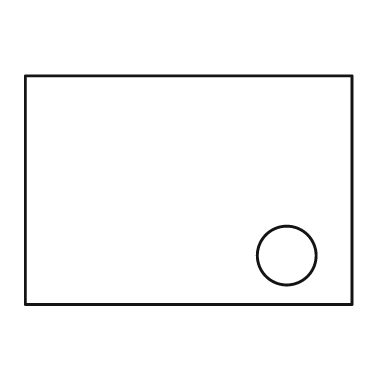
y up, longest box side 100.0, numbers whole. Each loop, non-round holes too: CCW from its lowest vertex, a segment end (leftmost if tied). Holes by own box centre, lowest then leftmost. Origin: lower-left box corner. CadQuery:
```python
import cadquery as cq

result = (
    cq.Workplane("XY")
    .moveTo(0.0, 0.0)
    .lineTo(100.0, 0.0)
    .lineTo(100.0, 70.0)
    .lineTo(0.0, 70.0)
    .close()
    .moveTo(80.0, 15.0)
    .circle(9.0)
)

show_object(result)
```